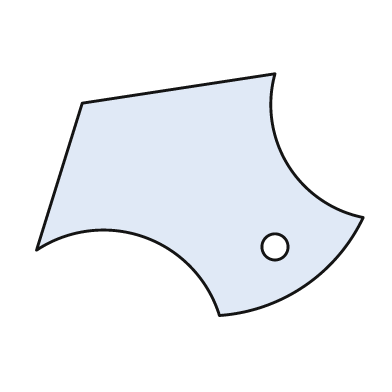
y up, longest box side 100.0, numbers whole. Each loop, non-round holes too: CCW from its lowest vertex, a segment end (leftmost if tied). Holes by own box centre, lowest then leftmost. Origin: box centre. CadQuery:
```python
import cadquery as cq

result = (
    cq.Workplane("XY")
    .moveTo(6.0, -37.0)
    .threePointArc((32.0, -28.0), (50.0, -7.0))
    .threePointArc((27.0, 9.0), (23.0, 37.0))
    .lineTo(-36.0, 28.0)
    .lineTo(-50.0, -17.0)
    .threePointArc((-17.0, -13.0), (6.0, -37.0))
    .close()
    .moveTo(23.0, -16.0)
    .circle(4.0)
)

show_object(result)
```